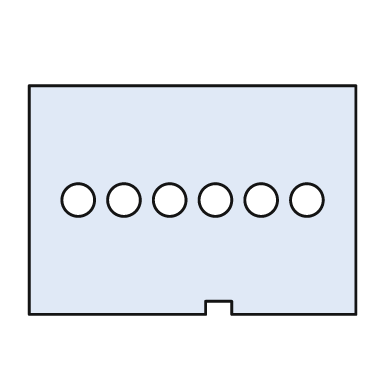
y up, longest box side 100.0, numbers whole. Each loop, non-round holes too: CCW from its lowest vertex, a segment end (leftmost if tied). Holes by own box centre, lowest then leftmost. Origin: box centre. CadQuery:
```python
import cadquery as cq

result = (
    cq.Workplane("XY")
    .moveTo(-50.0, -35.0)
    .lineTo(4.0, -35.0)
    .lineTo(4.0, -31.0)
    .lineTo(12.0, -31.0)
    .lineTo(12.0, -35.0)
    .lineTo(50.0, -35.0)
    .lineTo(50.0, 35.0)
    .lineTo(-50.0, 35.0)
    .close()
    .moveTo(-35.0, 0.0)
    .circle(5.0)
    .moveTo(-21.0, 0.0)
    .circle(5.0)
    .moveTo(-7.0, 0.0)
    .circle(5.0)
    .moveTo(7.0, 0.0)
    .circle(5.0)
    .moveTo(21.0, 0.0)
    .circle(5.0)
    .moveTo(35.0, 0.0)
    .circle(5.0)
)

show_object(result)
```